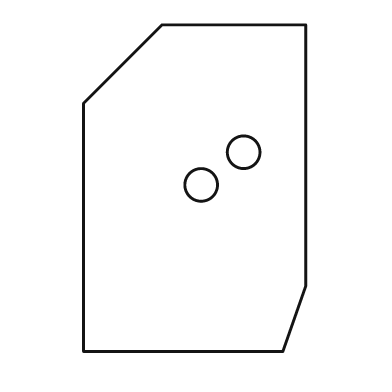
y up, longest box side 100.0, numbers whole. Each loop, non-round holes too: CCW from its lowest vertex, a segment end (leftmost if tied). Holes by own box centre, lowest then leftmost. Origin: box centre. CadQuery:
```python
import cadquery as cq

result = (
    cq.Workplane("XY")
    .moveTo(-34.0, -50.0)
    .lineTo(27.0, -50.0)
    .lineTo(34.0, -30.0)
    .lineTo(34.0, 50.0)
    .lineTo(-10.0, 50.0)
    .lineTo(-34.0, 26.0)
    .close()
    .moveTo(2.0, 1.0)
    .circle(5.0)
    .moveTo(15.0, 11.0)
    .circle(5.0)
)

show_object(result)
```